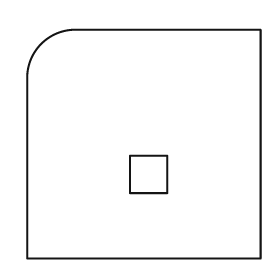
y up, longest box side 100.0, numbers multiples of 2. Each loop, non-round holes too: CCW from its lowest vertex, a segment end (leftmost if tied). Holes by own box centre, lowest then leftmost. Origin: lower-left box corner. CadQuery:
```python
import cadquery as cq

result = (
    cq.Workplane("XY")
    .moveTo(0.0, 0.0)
    .lineTo(100.0, 0.0)
    .lineTo(100.0, 98.0)
    .lineTo(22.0, 98.0)
    .threePointArc((6.0, 92.0), (0.0, 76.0))
    .close()
    .moveTo(44.0, 28.0)
    .lineTo(60.0, 28.0)
    .lineTo(60.0, 44.0)
    .lineTo(44.0, 44.0)
    .close()
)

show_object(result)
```